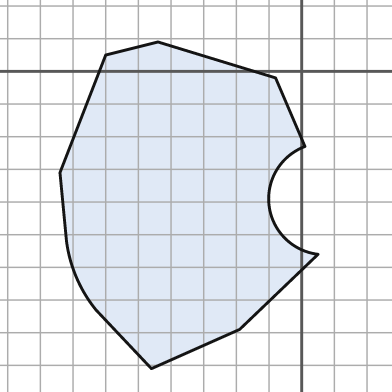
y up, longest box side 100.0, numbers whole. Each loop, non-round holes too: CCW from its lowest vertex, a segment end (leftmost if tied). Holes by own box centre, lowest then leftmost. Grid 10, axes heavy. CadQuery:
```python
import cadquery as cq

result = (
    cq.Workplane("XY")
    .moveTo(-46.0, -91.0)
    .lineTo(-19.0, -79.0)
    .lineTo(5.0, -56.0)
    .threePointArc((-10.0, -41.0), (1.0, -23.0))
    .lineTo(-8.0, -2.0)
    .lineTo(-44.0, 9.0)
    .lineTo(-60.0, 5.0)
    .lineTo(-74.0, -31.0)
    .lineTo(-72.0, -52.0)
    .threePointArc((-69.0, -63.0), (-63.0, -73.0))
    .close()
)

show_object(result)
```